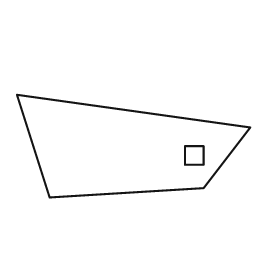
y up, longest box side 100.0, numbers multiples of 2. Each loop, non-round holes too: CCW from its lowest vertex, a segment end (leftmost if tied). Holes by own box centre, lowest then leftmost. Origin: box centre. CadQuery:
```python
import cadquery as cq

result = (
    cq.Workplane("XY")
    .moveTo(-36.0, -22.0)
    .lineTo(30.0, -18.0)
    .lineTo(50.0, 8.0)
    .lineTo(-50.0, 22.0)
    .close()
    .moveTo(22.0, -8.0)
    .lineTo(30.0, -8.0)
    .lineTo(30.0, 0.0)
    .lineTo(22.0, 0.0)
    .close()
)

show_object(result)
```